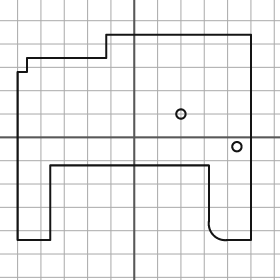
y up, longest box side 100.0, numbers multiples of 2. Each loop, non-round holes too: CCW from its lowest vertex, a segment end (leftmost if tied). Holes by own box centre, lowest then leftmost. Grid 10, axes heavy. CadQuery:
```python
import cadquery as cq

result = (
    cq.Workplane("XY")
    .moveTo(-50.0, -44.0)
    .lineTo(-36.0, -44.0)
    .lineTo(-36.0, -12.0)
    .lineTo(32.0, -12.0)
    .lineTo(32.0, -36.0)
    .threePointArc((34.0, -42.0), (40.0, -44.0))
    .lineTo(50.0, -44.0)
    .lineTo(50.0, 44.0)
    .lineTo(-12.0, 44.0)
    .lineTo(-12.0, 34.0)
    .lineTo(-46.0, 34.0)
    .lineTo(-46.0, 28.0)
    .lineTo(-50.0, 28.0)
    .close()
    .moveTo(44.0, -4.0)
    .circle(2.0)
    .moveTo(20.0, 10.0)
    .circle(2.0)
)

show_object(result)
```